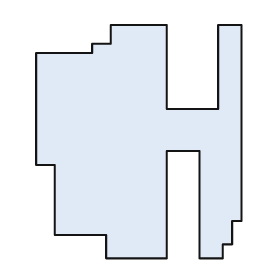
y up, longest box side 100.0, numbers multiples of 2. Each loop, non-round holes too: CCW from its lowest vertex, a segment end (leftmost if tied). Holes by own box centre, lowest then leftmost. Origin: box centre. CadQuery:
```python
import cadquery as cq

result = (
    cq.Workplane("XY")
    .moveTo(-14.0, -50.0)
    .lineTo(12.0, -50.0)
    .lineTo(12.0, -4.0)
    .lineTo(26.0, -4.0)
    .lineTo(26.0, -50.0)
    .lineTo(36.0, -50.0)
    .lineTo(36.0, -44.0)
    .lineTo(40.0, -44.0)
    .lineTo(40.0, -34.0)
    .lineTo(44.0, -34.0)
    .lineTo(44.0, 50.0)
    .lineTo(34.0, 50.0)
    .lineTo(34.0, 14.0)
    .lineTo(12.0, 14.0)
    .lineTo(12.0, 50.0)
    .lineTo(-12.0, 50.0)
    .lineTo(-12.0, 42.0)
    .lineTo(-20.0, 42.0)
    .lineTo(-20.0, 38.0)
    .lineTo(-44.0, 38.0)
    .lineTo(-44.0, -10.0)
    .lineTo(-36.0, -10.0)
    .lineTo(-36.0, -40.0)
    .lineTo(-14.0, -40.0)
    .close()
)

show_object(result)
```